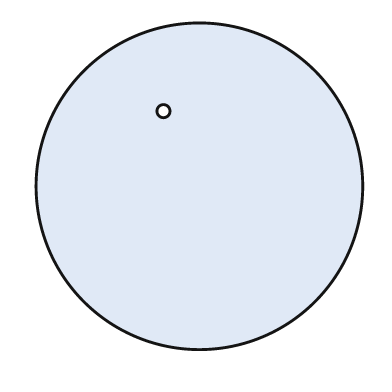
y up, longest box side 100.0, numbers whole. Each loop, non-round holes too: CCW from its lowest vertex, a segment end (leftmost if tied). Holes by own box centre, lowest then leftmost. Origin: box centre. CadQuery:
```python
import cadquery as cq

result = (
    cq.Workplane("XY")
    .moveTo(0.0, 0.0)
    .circle(50.0)
    .moveTo(-11.0, 23.0)
    .circle(2.0)
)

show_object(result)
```